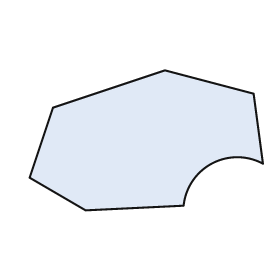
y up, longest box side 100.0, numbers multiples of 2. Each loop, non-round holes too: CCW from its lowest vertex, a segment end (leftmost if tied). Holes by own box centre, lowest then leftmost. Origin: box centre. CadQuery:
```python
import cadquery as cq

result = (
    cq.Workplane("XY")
    .moveTo(-26.0, -30.0)
    .lineTo(16.0, -28.0)
    .threePointArc((28.0, -10.0), (50.0, -10.0))
    .lineTo(46.0, 20.0)
    .lineTo(8.0, 30.0)
    .lineTo(-40.0, 14.0)
    .lineTo(-50.0, -16.0)
    .close()
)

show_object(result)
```